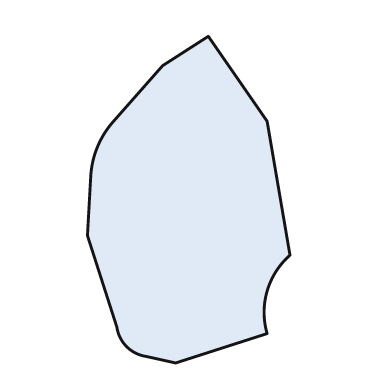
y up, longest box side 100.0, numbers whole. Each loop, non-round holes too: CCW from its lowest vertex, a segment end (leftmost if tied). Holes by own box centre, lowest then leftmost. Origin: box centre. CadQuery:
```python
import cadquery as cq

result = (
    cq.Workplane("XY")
    .moveTo(-4.0, -50.0)
    .lineTo(24.0, -41.0)
    .threePointArc((24.0, -28.0), (31.0, -17.0))
    .lineTo(24.0, 24.0)
    .lineTo(6.0, 50.0)
    .lineTo(-8.0, 41.0)
    .lineTo(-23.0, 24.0)
    .threePointArc((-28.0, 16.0), (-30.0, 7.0))
    .lineTo(-31.0, -11.0)
    .lineTo(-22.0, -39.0)
    .threePointArc((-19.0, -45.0), (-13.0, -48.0))
    .close()
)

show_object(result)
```